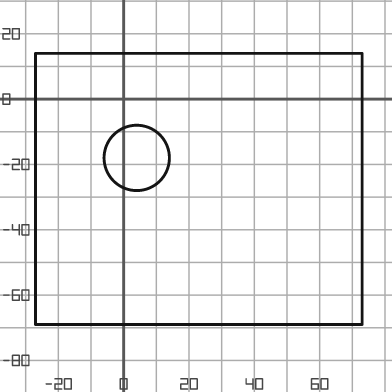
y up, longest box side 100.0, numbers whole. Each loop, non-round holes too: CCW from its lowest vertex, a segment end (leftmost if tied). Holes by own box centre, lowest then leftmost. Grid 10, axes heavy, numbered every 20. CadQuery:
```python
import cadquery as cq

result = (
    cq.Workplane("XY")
    .moveTo(-27.0, -69.0)
    .lineTo(73.0, -69.0)
    .lineTo(73.0, 14.0)
    .lineTo(-27.0, 14.0)
    .close()
    .moveTo(4.0, -18.0)
    .circle(10.0)
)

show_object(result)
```